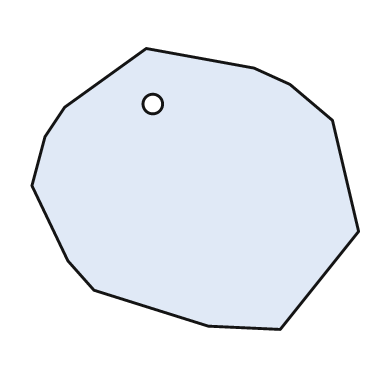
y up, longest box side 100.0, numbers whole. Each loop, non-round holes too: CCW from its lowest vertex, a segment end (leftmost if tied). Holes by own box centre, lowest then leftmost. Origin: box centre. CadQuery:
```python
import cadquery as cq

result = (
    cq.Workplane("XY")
    .moveTo(26.0, -43.0)
    .lineTo(50.0, -13.0)
    .lineTo(42.0, 21.0)
    .lineTo(29.0, 32.0)
    .lineTo(18.0, 37.0)
    .lineTo(-15.0, 43.0)
    .lineTo(-40.0, 25.0)
    .lineTo(-46.0, 16.0)
    .lineTo(-50.0, 1.0)
    .lineTo(-39.0, -22.0)
    .lineTo(-31.0, -31.0)
    .lineTo(4.0, -42.0)
    .close()
    .moveTo(-13.0, 26.0)
    .circle(3.0)
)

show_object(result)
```